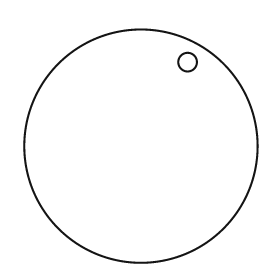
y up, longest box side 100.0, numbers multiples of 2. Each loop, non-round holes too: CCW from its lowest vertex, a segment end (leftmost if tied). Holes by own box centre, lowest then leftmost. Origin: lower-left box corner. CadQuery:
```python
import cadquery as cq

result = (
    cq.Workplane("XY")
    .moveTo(50.0, 50.0)
    .circle(50.0)
    .moveTo(70.0, 86.0)
    .circle(4.0)
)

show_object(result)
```